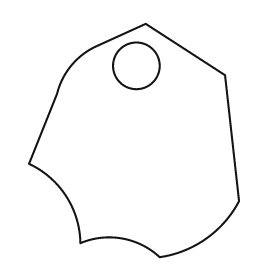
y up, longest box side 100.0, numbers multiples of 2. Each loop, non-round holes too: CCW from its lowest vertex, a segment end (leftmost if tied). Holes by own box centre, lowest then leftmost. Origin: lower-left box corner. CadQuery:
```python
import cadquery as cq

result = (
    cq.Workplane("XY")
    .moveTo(56.0, 0.0)
    .threePointArc((76.0, 8.0), (90.0, 24.0))
    .lineTo(84.0, 78.0)
    .lineTo(50.0, 100.0)
    .lineTo(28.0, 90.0)
    .threePointArc((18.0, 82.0), (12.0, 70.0))
    .lineTo(0.0, 40.0)
    .threePointArc((16.0, 26.0), (22.0, 6.0))
    .threePointArc((40.0, 8.0), (56.0, 0.0))
    .close()
    .moveTo(46.0, 82.0)
    .circle(10.0)
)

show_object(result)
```